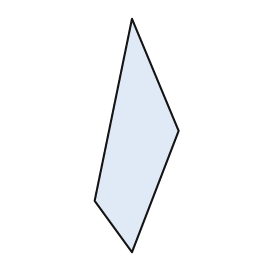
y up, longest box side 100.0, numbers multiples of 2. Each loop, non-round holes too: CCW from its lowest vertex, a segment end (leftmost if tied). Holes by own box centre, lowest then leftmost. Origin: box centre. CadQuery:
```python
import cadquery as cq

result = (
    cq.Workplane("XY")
    .moveTo(-2.0, -50.0)
    .lineTo(18.0, 2.0)
    .lineTo(-2.0, 50.0)
    .lineTo(-18.0, -28.0)
    .close()
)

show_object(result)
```